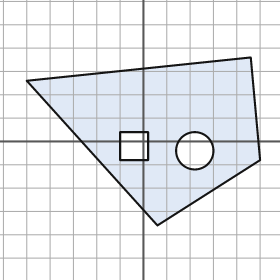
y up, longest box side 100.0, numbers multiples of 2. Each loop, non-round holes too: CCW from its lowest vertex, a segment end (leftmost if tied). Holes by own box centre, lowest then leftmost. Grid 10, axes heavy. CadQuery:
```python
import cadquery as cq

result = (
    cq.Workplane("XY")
    .moveTo(6.0, -36.0)
    .lineTo(50.0, -8.0)
    .lineTo(46.0, 36.0)
    .lineTo(-50.0, 26.0)
    .close()
    .moveTo(22.0, -4.0)
    .circle(8.0)
    .moveTo(-10.0, -8.0)
    .lineTo(2.0, -8.0)
    .lineTo(2.0, 4.0)
    .lineTo(-10.0, 4.0)
    .close()
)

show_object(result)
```